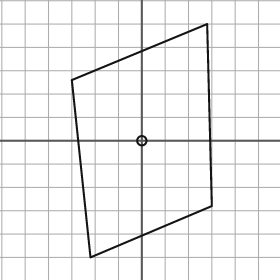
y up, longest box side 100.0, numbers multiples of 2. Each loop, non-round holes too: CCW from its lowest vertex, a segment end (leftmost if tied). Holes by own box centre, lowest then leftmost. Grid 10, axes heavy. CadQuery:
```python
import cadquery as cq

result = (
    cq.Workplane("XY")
    .moveTo(-22.0, -50.0)
    .lineTo(30.0, -28.0)
    .lineTo(28.0, 50.0)
    .lineTo(-30.0, 26.0)
    .close()
    .moveTo(0.0, 0.0)
    .circle(2.0)
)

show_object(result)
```